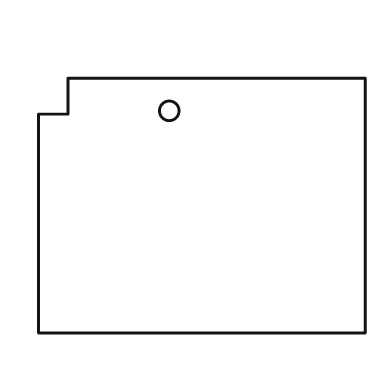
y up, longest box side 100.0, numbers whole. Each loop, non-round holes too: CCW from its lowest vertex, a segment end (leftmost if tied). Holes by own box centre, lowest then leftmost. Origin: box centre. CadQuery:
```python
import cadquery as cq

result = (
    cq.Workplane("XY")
    .moveTo(-50.0, -39.0)
    .lineTo(50.0, -39.0)
    .lineTo(50.0, 39.0)
    .lineTo(-41.0, 39.0)
    .lineTo(-41.0, 28.0)
    .lineTo(-50.0, 28.0)
    .close()
    .moveTo(-10.0, 29.0)
    .circle(3.0)
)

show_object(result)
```